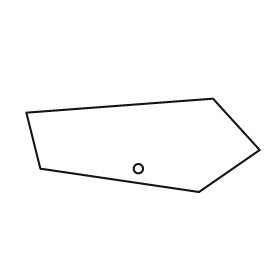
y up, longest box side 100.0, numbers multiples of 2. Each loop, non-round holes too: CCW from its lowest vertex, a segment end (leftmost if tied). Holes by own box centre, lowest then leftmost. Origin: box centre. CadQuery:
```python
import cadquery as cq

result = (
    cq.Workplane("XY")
    .moveTo(24.0, -20.0)
    .lineTo(50.0, -2.0)
    .lineTo(30.0, 20.0)
    .lineTo(-50.0, 14.0)
    .lineTo(-44.0, -10.0)
    .close()
    .moveTo(-2.0, -10.0)
    .circle(2.0)
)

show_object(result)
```